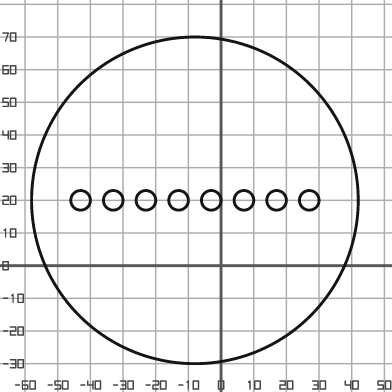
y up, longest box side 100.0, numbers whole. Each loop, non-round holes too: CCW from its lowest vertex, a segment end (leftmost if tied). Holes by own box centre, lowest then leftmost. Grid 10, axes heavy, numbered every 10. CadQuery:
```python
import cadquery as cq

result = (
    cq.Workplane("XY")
    .moveTo(-8.0, 20.0)
    .circle(50.0)
    .moveTo(-43.0, 20.0)
    .circle(3.0)
    .moveTo(-33.0, 20.0)
    .circle(3.0)
    .moveTo(-23.0, 20.0)
    .circle(3.0)
    .moveTo(-13.0, 20.0)
    .circle(3.0)
    .moveTo(-3.0, 20.0)
    .circle(3.0)
    .moveTo(7.0, 20.0)
    .circle(3.0)
    .moveTo(17.0, 20.0)
    .circle(3.0)
    .moveTo(27.0, 20.0)
    .circle(3.0)
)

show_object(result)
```